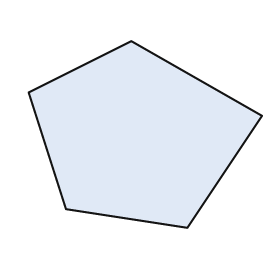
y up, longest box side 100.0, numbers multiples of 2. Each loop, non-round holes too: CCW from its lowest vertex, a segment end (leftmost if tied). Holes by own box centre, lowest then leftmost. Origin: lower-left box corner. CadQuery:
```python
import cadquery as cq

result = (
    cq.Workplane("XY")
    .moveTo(68.0, 0.0)
    .lineTo(100.0, 48.0)
    .lineTo(44.0, 80.0)
    .lineTo(0.0, 58.0)
    .lineTo(16.0, 8.0)
    .close()
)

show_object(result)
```